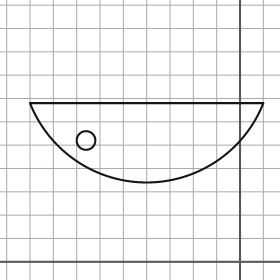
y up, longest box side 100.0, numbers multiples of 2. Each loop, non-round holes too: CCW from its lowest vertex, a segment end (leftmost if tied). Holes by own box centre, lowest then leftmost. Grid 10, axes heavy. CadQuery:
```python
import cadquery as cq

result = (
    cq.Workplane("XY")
    .moveTo(-90.0, 68.0)
    .threePointArc((-40.0, 34.0), (10.0, 68.0))
    .close()
    .moveTo(-66.0, 52.0)
    .circle(4.0)
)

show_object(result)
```